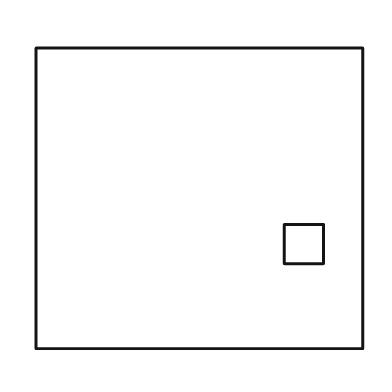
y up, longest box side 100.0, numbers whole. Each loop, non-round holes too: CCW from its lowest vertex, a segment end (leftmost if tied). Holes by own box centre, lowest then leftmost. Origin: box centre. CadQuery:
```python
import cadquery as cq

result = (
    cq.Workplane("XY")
    .moveTo(-50.0, -46.0)
    .lineTo(50.0, -46.0)
    .lineTo(50.0, 46.0)
    .lineTo(-50.0, 46.0)
    .close()
    .moveTo(26.0, -20.0)
    .lineTo(38.0, -20.0)
    .lineTo(38.0, -8.0)
    .lineTo(26.0, -8.0)
    .close()
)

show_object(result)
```